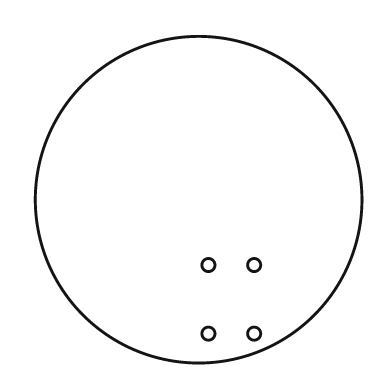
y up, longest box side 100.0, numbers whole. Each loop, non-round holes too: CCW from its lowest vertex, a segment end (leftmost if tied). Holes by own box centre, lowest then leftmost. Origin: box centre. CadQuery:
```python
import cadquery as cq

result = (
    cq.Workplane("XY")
    .moveTo(0.0, 0.0)
    .circle(50.0)
    .moveTo(3.0, -41.0)
    .circle(2.0)
    .moveTo(17.0, -41.0)
    .circle(2.0)
    .moveTo(3.0, -20.0)
    .circle(2.0)
    .moveTo(17.0, -20.0)
    .circle(2.0)
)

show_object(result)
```